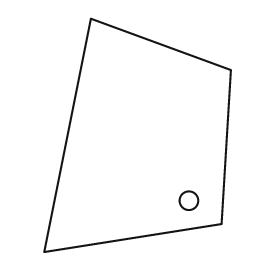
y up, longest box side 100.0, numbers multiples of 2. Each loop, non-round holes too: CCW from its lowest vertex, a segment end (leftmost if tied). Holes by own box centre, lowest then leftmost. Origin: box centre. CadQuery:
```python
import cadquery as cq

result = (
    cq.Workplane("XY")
    .moveTo(-40.0, -50.0)
    .lineTo(36.0, -38.0)
    .lineTo(40.0, 28.0)
    .lineTo(-20.0, 50.0)
    .close()
    .moveTo(22.0, -28.0)
    .circle(4.0)
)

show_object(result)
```